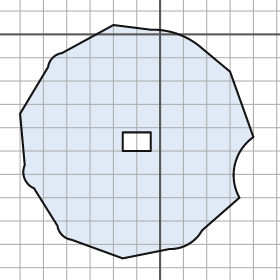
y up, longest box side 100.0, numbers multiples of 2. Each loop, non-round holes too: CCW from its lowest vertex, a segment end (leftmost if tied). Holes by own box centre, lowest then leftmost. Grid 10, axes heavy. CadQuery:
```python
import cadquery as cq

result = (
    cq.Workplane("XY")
    .moveTo(-16.0, -96.0)
    .lineTo(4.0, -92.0)
    .threePointArc((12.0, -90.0), (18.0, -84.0))
    .lineTo(34.0, -70.0)
    .threePointArc((32.0, -56.0), (40.0, -44.0))
    .lineTo(30.0, -16.0)
    .lineTo(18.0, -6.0)
    .threePointArc((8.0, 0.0), (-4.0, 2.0))
    .lineTo(-20.0, 4.0)
    .lineTo(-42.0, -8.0)
    .threePointArc((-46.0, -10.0), (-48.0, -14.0))
    .lineTo(-60.0, -34.0)
    .lineTo(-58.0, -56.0)
    .threePointArc((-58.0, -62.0), (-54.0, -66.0))
    .lineTo(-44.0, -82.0)
    .threePointArc((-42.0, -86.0), (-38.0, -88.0))
    .close()
    .moveTo(-16.0, -50.0)
    .lineTo(-4.0, -50.0)
    .lineTo(-4.0, -42.0)
    .lineTo(-16.0, -42.0)
    .close()
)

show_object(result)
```